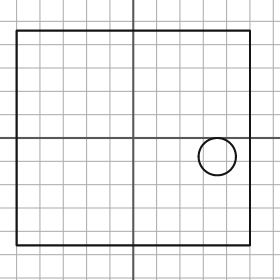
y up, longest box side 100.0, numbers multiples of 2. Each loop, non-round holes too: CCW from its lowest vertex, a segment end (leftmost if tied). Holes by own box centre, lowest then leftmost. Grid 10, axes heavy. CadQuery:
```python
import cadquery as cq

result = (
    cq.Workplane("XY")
    .moveTo(-50.0, -46.0)
    .lineTo(50.0, -46.0)
    .lineTo(50.0, 46.0)
    .lineTo(-50.0, 46.0)
    .close()
    .moveTo(36.0, -8.0)
    .circle(8.0)
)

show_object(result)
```